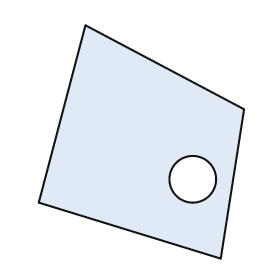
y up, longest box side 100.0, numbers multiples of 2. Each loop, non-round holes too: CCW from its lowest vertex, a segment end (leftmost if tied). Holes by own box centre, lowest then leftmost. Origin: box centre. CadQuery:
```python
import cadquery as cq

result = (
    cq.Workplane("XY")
    .moveTo(34.0, -50.0)
    .lineTo(44.0, 14.0)
    .lineTo(-24.0, 50.0)
    .lineTo(-44.0, -26.0)
    .close()
    .moveTo(22.0, -16.0)
    .circle(10.0)
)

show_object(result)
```